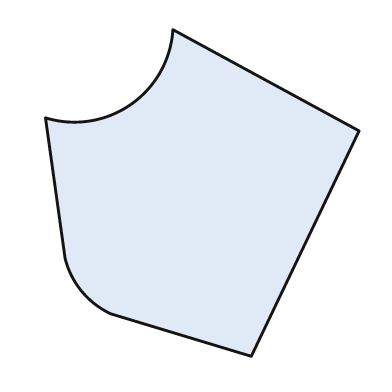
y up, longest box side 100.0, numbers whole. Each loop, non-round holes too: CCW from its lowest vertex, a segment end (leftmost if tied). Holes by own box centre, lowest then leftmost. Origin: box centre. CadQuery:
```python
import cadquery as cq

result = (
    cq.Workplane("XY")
    .moveTo(15.0, -50.0)
    .lineTo(48.0, 19.0)
    .lineTo(-9.0, 50.0)
    .threePointArc((-22.0, 27.0), (-48.0, 23.0))
    .lineTo(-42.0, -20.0)
    .threePointArc((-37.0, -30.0), (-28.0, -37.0))
    .close()
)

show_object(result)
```